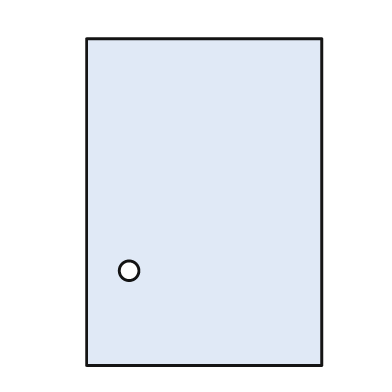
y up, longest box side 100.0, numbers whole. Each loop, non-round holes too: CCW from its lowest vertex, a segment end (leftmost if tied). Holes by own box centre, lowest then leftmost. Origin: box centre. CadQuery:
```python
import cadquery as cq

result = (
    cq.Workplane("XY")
    .moveTo(-36.0, -50.0)
    .lineTo(36.0, -50.0)
    .lineTo(36.0, 50.0)
    .lineTo(-36.0, 50.0)
    .close()
    .moveTo(-23.0, -21.0)
    .circle(3.0)
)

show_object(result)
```